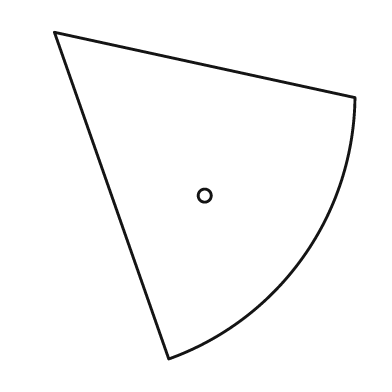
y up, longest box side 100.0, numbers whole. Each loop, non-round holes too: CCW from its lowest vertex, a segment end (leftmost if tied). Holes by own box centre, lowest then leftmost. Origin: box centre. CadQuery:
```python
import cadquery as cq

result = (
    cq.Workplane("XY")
    .moveTo(-11.0, -50.0)
    .threePointArc((30.0, -19.0), (46.0, 30.0))
    .lineTo(-46.0, 50.0)
    .close()
    .moveTo(0.0, 0.0)
    .circle(2.0)
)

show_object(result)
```